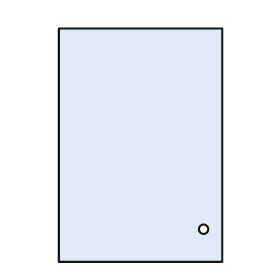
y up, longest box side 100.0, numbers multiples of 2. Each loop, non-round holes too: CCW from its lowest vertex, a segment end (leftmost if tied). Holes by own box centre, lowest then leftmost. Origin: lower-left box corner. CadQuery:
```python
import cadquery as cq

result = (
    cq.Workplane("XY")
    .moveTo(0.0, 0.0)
    .lineTo(70.0, 0.0)
    .lineTo(70.0, 100.0)
    .lineTo(0.0, 100.0)
    .close()
    .moveTo(62.0, 14.0)
    .circle(2.0)
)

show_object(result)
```